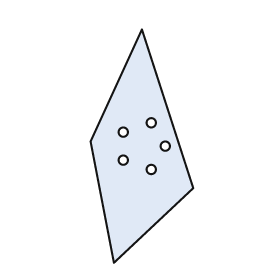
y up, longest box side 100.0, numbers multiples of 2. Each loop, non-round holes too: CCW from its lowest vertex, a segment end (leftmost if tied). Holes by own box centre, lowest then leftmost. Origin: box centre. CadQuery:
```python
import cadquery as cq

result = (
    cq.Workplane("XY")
    .moveTo(-12.0, -50.0)
    .lineTo(22.0, -18.0)
    .lineTo(0.0, 50.0)
    .lineTo(-22.0, 2.0)
    .close()
    .moveTo(4.0, -10.0)
    .circle(2.0)
    .moveTo(-8.0, -6.0)
    .circle(2.0)
    .moveTo(10.0, 0.0)
    .circle(2.0)
    .moveTo(-8.0, 6.0)
    .circle(2.0)
    .moveTo(4.0, 10.0)
    .circle(2.0)
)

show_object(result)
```